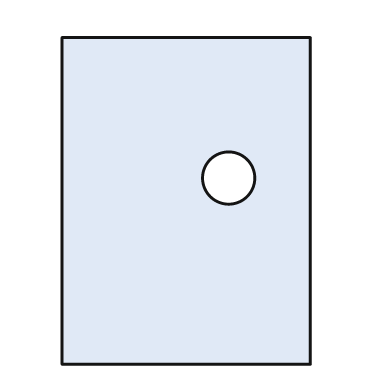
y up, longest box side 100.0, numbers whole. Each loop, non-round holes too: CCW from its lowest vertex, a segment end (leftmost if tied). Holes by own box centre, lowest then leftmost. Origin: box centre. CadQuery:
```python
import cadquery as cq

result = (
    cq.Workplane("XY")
    .moveTo(-38.0, -50.0)
    .lineTo(38.0, -50.0)
    .lineTo(38.0, 50.0)
    .lineTo(-38.0, 50.0)
    .close()
    .moveTo(13.0, 7.0)
    .circle(8.0)
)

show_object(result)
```